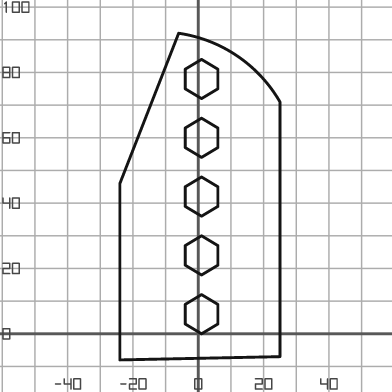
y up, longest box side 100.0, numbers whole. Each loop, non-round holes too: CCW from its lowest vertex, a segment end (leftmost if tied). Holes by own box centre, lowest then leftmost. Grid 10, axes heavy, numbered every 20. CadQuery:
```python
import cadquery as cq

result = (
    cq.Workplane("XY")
    .moveTo(-24.0, -8.0)
    .lineTo(25.0, -7.0)
    .lineTo(25.0, 71.0)
    .threePointArc((12.0, 85.0), (-6.0, 92.0))
    .lineTo(-24.0, 46.0)
    .close()
    .moveTo(1.0, 0.0)
    .lineTo(6.0, 3.0)
    .lineTo(6.0, 9.0)
    .lineTo(1.0, 12.0)
    .lineTo(-4.0, 9.0)
    .lineTo(-4.0, 3.0)
    .close()
    .moveTo(1.0, 18.0)
    .lineTo(6.0, 21.0)
    .lineTo(6.0, 27.0)
    .lineTo(1.0, 30.0)
    .lineTo(-4.0, 27.0)
    .lineTo(-4.0, 21.0)
    .close()
    .moveTo(1.0, 36.0)
    .lineTo(6.0, 39.0)
    .lineTo(6.0, 45.0)
    .lineTo(1.0, 48.0)
    .lineTo(-4.0, 45.0)
    .lineTo(-4.0, 39.0)
    .close()
    .moveTo(1.0, 54.0)
    .lineTo(6.0, 57.0)
    .lineTo(6.0, 63.0)
    .lineTo(1.0, 66.0)
    .lineTo(-4.0, 63.0)
    .lineTo(-4.0, 57.0)
    .close()
    .moveTo(1.0, 72.0)
    .lineTo(6.0, 75.0)
    .lineTo(6.0, 81.0)
    .lineTo(1.0, 84.0)
    .lineTo(-4.0, 81.0)
    .lineTo(-4.0, 75.0)
    .close()
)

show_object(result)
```